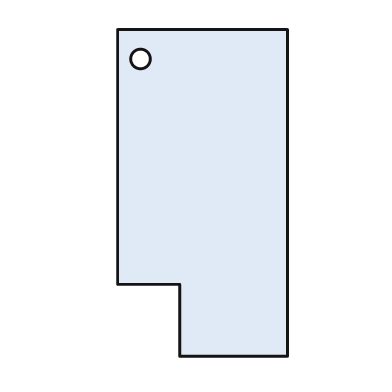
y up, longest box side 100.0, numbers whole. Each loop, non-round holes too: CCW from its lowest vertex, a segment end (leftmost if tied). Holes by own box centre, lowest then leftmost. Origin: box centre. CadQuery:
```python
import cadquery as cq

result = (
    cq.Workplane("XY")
    .moveTo(-7.0, -50.0)
    .lineTo(26.0, -50.0)
    .lineTo(26.0, 50.0)
    .lineTo(-26.0, 50.0)
    .lineTo(-26.0, -28.0)
    .lineTo(-7.0, -28.0)
    .close()
    .moveTo(-19.0, 41.0)
    .circle(3.0)
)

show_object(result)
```